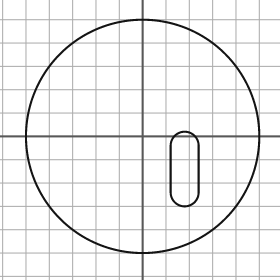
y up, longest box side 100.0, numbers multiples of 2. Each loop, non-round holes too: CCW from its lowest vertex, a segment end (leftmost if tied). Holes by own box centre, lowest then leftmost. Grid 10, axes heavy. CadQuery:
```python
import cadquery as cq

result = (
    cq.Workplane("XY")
    .moveTo(0.0, 0.0)
    .circle(50.0)
    .moveTo(12.0, -24.0)
    .threePointArc((18.0, -30.0), (24.0, -24.0))
    .lineTo(24.0, -4.0)
    .threePointArc((18.0, 2.0), (12.0, -4.0))
    .close()
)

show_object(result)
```